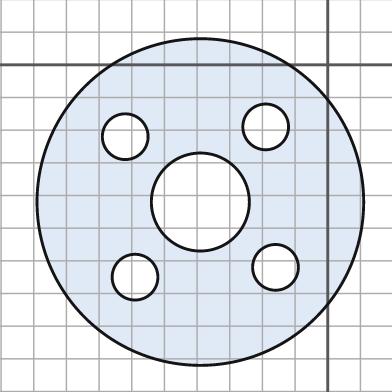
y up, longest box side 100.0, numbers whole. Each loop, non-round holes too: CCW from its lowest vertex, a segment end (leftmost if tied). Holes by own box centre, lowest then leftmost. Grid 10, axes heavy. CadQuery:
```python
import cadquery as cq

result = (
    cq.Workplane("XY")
    .moveTo(-39.0, -42.0)
    .circle(50.0)
    .moveTo(-59.0, -65.0)
    .circle(7.0)
    .moveTo(-16.0, -62.0)
    .circle(7.0)
    .moveTo(-39.0, -42.0)
    .circle(15.0)
    .moveTo(-62.0, -22.0)
    .circle(7.0)
    .moveTo(-19.0, -19.0)
    .circle(7.0)
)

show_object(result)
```